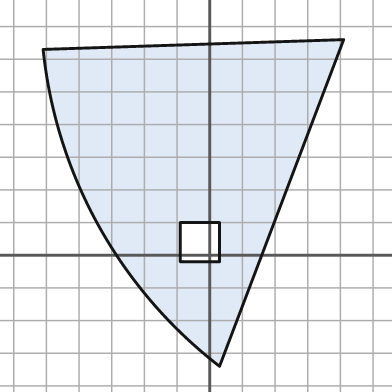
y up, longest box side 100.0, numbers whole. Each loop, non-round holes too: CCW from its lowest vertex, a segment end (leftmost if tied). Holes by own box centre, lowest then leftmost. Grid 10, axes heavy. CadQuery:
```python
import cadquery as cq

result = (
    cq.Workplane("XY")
    .moveTo(3.0, -34.0)
    .lineTo(41.0, 66.0)
    .lineTo(-51.0, 63.0)
    .threePointArc((-34.0, 9.0), (3.0, -34.0))
    .close()
    .moveTo(-9.0, -2.0)
    .lineTo(3.0, -2.0)
    .lineTo(3.0, 10.0)
    .lineTo(-9.0, 10.0)
    .close()
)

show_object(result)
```